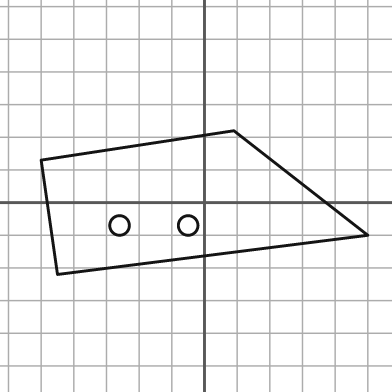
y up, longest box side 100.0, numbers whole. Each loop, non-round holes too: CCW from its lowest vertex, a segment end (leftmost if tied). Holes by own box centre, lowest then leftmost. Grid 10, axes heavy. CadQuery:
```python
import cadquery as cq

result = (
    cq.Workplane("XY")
    .moveTo(-45.0, -22.0)
    .lineTo(50.0, -10.0)
    .lineTo(9.0, 22.0)
    .lineTo(-50.0, 13.0)
    .close()
    .moveTo(-26.0, -7.0)
    .circle(3.0)
    .moveTo(-5.0, -7.0)
    .circle(3.0)
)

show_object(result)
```